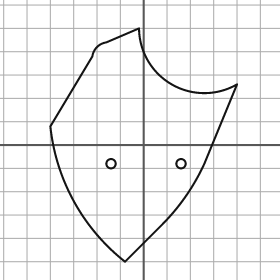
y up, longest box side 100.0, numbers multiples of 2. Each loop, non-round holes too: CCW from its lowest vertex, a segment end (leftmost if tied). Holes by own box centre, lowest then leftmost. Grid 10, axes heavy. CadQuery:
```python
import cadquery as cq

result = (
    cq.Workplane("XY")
    .moveTo(-8.0, -50.0)
    .lineTo(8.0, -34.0)
    .threePointArc((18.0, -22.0), (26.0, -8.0))
    .lineTo(40.0, 26.0)
    .threePointArc((12.0, 26.0), (-2.0, 50.0))
    .lineTo(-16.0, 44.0)
    .threePointArc((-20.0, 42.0), (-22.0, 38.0))
    .lineTo(-40.0, 8.0)
    .threePointArc((-30.0, -24.0), (-8.0, -50.0))
    .close()
    .moveTo(-14.0, -8.0)
    .circle(2.0)
    .moveTo(16.0, -8.0)
    .circle(2.0)
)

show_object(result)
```